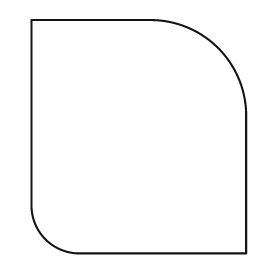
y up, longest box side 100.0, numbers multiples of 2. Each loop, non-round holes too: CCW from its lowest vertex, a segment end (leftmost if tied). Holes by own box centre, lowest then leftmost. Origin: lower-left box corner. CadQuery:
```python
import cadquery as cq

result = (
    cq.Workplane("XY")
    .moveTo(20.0, 0.0)
    .lineTo(92.0, 0.0)
    .lineTo(92.0, 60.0)
    .threePointArc((80.0, 88.0), (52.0, 100.0))
    .lineTo(0.0, 100.0)
    .lineTo(0.0, 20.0)
    .threePointArc((6.0, 6.0), (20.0, 0.0))
    .close()
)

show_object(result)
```